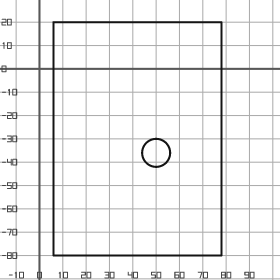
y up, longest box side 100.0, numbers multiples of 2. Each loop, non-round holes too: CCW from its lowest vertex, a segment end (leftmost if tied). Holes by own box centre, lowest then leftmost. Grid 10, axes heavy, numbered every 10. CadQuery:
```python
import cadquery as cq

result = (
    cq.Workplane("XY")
    .moveTo(6.0, -80.0)
    .lineTo(78.0, -80.0)
    .lineTo(78.0, 20.0)
    .lineTo(6.0, 20.0)
    .close()
    .moveTo(50.0, -36.0)
    .circle(6.0)
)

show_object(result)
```